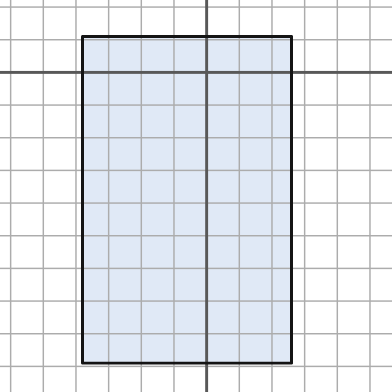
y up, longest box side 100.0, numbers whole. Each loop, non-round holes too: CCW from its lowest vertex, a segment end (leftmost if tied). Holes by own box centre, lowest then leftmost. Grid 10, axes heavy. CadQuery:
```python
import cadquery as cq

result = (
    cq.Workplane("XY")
    .moveTo(-38.0, -89.0)
    .lineTo(26.0, -89.0)
    .lineTo(26.0, 11.0)
    .lineTo(-38.0, 11.0)
    .close()
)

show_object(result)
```